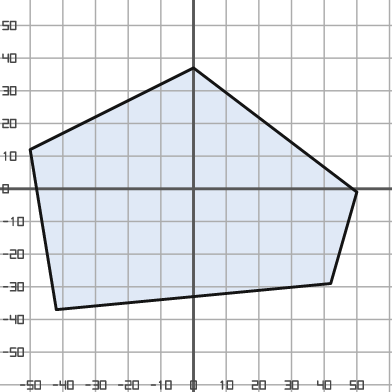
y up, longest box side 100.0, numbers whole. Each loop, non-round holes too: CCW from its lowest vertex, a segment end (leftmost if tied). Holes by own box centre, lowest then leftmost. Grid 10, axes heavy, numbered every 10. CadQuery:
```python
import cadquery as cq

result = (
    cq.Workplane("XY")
    .moveTo(-42.0, -37.0)
    .lineTo(42.0, -29.0)
    .lineTo(50.0, -1.0)
    .lineTo(0.0, 37.0)
    .lineTo(-50.0, 12.0)
    .close()
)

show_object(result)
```